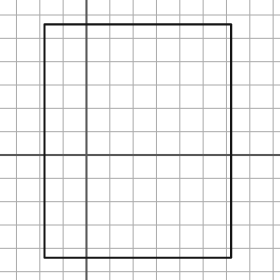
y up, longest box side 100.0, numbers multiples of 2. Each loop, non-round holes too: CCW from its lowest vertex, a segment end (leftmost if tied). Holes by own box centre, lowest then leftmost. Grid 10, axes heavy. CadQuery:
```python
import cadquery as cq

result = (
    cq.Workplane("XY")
    .moveTo(-18.0, -44.0)
    .lineTo(62.0, -44.0)
    .lineTo(62.0, 56.0)
    .lineTo(-18.0, 56.0)
    .close()
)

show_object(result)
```